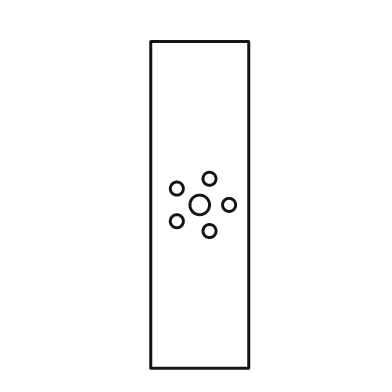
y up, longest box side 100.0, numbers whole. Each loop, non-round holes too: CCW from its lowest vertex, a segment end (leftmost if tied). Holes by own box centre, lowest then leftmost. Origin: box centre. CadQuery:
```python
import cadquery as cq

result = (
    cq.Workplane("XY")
    .moveTo(-15.0, -50.0)
    .lineTo(15.0, -50.0)
    .lineTo(15.0, 50.0)
    .lineTo(-15.0, 50.0)
    .close()
    .moveTo(3.0, -8.0)
    .circle(2.0)
    .moveTo(-7.0, -5.0)
    .circle(2.0)
    .moveTo(0.0, 0.0)
    .circle(3.0)
    .moveTo(9.0, 0.0)
    .circle(2.0)
    .moveTo(-7.0, 5.0)
    .circle(2.0)
    .moveTo(3.0, 8.0)
    .circle(2.0)
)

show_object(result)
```